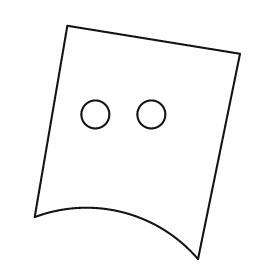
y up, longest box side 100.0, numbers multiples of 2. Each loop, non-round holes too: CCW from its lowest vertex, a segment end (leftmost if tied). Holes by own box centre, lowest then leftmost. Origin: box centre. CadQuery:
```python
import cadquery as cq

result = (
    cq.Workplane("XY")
    .moveTo(26.0, -50.0)
    .lineTo(44.0, 38.0)
    .lineTo(-30.0, 50.0)
    .lineTo(-44.0, -32.0)
    .threePointArc((-6.0, -30.0), (26.0, -50.0))
    .close()
    .moveTo(-18.0, 12.0)
    .circle(6.0)
    .moveTo(6.0, 12.0)
    .circle(6.0)
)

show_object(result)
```